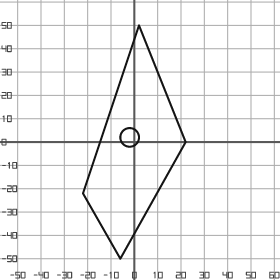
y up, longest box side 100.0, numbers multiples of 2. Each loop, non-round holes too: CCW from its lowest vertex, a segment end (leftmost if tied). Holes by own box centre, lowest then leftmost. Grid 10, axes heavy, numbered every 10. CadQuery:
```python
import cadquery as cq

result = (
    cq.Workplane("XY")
    .moveTo(-6.0, -50.0)
    .lineTo(22.0, 0.0)
    .lineTo(2.0, 50.0)
    .lineTo(-22.0, -22.0)
    .close()
    .moveTo(-2.0, 2.0)
    .circle(4.0)
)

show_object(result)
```